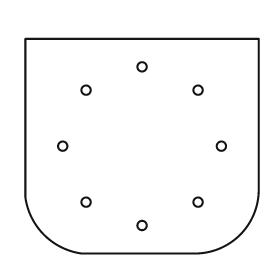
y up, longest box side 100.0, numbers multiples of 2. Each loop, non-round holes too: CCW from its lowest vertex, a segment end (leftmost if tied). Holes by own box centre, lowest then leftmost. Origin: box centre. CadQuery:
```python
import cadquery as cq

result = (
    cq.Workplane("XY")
    .moveTo(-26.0, -46.0)
    .lineTo(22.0, -46.0)
    .threePointArc((42.0, -38.0), (50.0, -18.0))
    .lineTo(50.0, 46.0)
    .lineTo(-50.0, 46.0)
    .lineTo(-50.0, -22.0)
    .threePointArc((-42.0, -38.0), (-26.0, -46.0))
    .close()
    .moveTo(0.0, -34.0)
    .circle(2.0)
    .moveTo(-24.0, -24.0)
    .circle(2.0)
    .moveTo(24.0, -24.0)
    .circle(2.0)
    .moveTo(-34.0, 0.0)
    .circle(2.0)
    .moveTo(34.0, 0.0)
    .circle(2.0)
    .moveTo(-24.0, 24.0)
    .circle(2.0)
    .moveTo(24.0, 24.0)
    .circle(2.0)
    .moveTo(0.0, 34.0)
    .circle(2.0)
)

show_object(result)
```